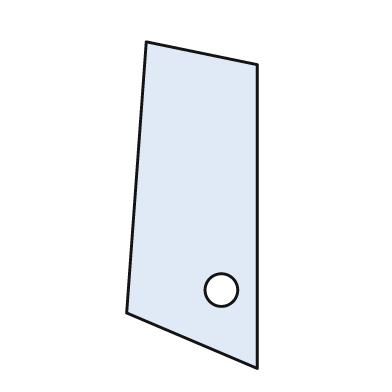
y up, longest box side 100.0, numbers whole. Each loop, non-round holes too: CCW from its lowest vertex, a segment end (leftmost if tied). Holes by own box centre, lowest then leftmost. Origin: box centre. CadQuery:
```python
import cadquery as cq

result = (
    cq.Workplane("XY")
    .moveTo(20.0, -50.0)
    .lineTo(20.0, 43.0)
    .lineTo(-14.0, 50.0)
    .lineTo(-20.0, -33.0)
    .close()
    .moveTo(9.0, -26.0)
    .circle(5.0)
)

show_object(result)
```